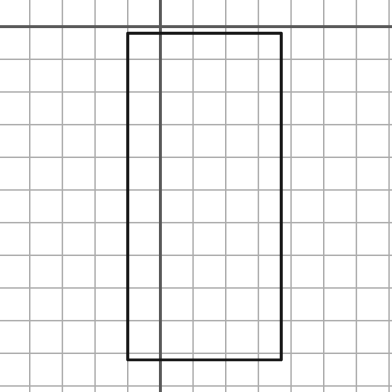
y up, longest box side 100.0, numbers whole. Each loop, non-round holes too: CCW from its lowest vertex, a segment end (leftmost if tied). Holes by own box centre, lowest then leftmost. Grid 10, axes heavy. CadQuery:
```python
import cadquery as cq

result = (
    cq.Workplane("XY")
    .moveTo(-10.0, -102.0)
    .lineTo(37.0, -102.0)
    .lineTo(37.0, -2.0)
    .lineTo(-10.0, -2.0)
    .close()
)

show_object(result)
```